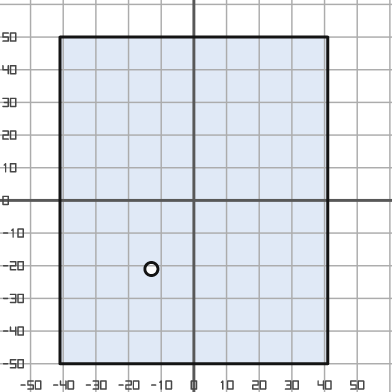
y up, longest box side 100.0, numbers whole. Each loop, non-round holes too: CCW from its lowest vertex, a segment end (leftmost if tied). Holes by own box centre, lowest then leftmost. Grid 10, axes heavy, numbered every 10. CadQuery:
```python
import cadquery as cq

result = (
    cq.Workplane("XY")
    .moveTo(-41.0, -50.0)
    .lineTo(41.0, -50.0)
    .lineTo(41.0, 50.0)
    .lineTo(-41.0, 50.0)
    .close()
    .moveTo(-13.0, -21.0)
    .circle(2.0)
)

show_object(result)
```